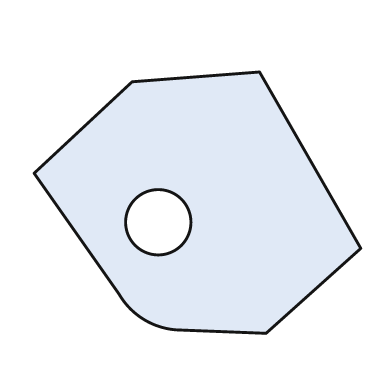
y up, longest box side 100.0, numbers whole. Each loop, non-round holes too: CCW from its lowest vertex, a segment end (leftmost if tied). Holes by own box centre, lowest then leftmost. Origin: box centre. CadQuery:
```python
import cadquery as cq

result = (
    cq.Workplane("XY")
    .moveTo(21.0, -40.0)
    .lineTo(50.0, -14.0)
    .lineTo(19.0, 40.0)
    .lineTo(-20.0, 37.0)
    .lineTo(-50.0, 9.0)
    .lineTo(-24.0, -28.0)
    .threePointArc((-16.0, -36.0), (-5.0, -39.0))
    .close()
    .moveTo(-12.0, -6.0)
    .circle(10.0)
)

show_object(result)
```